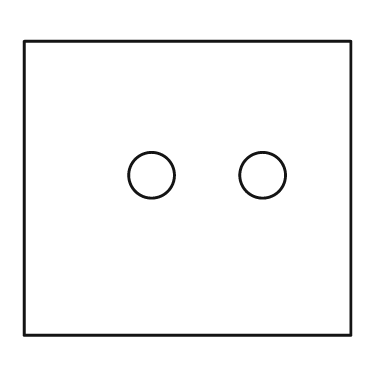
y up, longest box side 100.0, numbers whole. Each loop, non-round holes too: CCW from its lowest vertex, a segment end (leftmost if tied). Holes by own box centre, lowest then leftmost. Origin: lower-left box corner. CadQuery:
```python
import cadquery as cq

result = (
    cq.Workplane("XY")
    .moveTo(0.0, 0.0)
    .lineTo(100.0, 0.0)
    .lineTo(100.0, 90.0)
    .lineTo(0.0, 90.0)
    .close()
    .moveTo(39.0, 49.0)
    .circle(7.0)
    .moveTo(73.0, 49.0)
    .circle(7.0)
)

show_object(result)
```